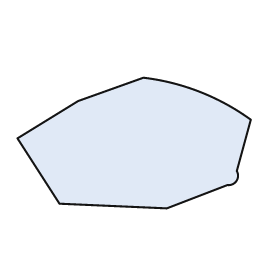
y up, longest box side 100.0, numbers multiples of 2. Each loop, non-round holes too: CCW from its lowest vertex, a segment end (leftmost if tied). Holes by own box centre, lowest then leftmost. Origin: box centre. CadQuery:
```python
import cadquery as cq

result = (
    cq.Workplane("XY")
    .moveTo(14.0, -28.0)
    .lineTo(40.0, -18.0)
    .threePointArc((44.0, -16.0), (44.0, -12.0))
    .lineTo(50.0, 10.0)
    .threePointArc((28.0, 22.0), (4.0, 28.0))
    .lineTo(-24.0, 18.0)
    .lineTo(-50.0, 2.0)
    .lineTo(-32.0, -26.0)
    .close()
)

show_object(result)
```